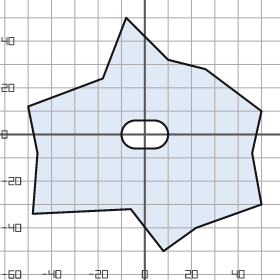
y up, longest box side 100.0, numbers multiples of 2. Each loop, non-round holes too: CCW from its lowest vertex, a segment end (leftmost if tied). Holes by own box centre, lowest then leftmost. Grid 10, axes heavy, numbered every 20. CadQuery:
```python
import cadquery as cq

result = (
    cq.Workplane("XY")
    .moveTo(8.0, -50.0)
    .lineTo(22.0, -40.0)
    .lineTo(50.0, -30.0)
    .lineTo(46.0, -8.0)
    .lineTo(50.0, 10.0)
    .lineTo(26.0, 28.0)
    .lineTo(10.0, 32.0)
    .lineTo(-8.0, 50.0)
    .lineTo(-18.0, 24.0)
    .lineTo(-50.0, 12.0)
    .lineTo(-46.0, -8.0)
    .lineTo(-48.0, -34.0)
    .lineTo(-6.0, -32.0)
    .close()
    .moveTo(-4.0, -6.0)
    .lineTo(4.0, -6.0)
    .threePointArc((10.0, 0.0), (4.0, 6.0))
    .lineTo(-4.0, 6.0)
    .threePointArc((-10.0, 0.0), (-4.0, -6.0))
    .close()
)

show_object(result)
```